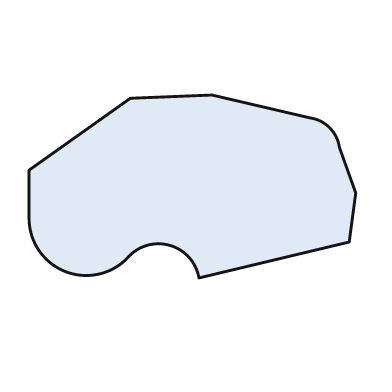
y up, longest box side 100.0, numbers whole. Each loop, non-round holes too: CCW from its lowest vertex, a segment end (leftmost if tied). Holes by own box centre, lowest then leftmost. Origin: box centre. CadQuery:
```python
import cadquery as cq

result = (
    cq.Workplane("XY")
    .moveTo(2.0, -28.0)
    .lineTo(48.0, -17.0)
    .lineTo(50.0, -2.0)
    .lineTo(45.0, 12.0)
    .threePointArc((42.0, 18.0), (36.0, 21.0))
    .lineTo(6.0, 28.0)
    .lineTo(-19.0, 27.0)
    .lineTo(-50.0, 5.0)
    .lineTo(-50.0, -10.0)
    .threePointArc((-39.0, -26.0), (-20.0, -22.0))
    .threePointArc((-7.0, -18.0), (2.0, -28.0))
    .close()
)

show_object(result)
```